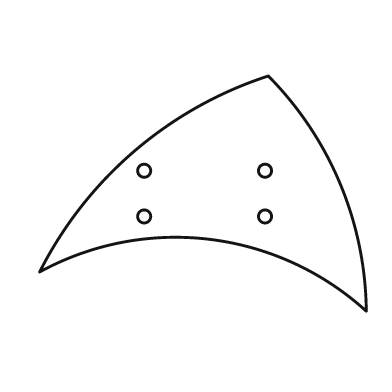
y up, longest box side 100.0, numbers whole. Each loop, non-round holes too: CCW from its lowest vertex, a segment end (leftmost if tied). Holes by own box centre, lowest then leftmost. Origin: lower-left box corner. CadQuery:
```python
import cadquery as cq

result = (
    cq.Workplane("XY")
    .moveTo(100.0, 0.0)
    .threePointArc((92.0, 39.0), (70.0, 72.0))
    .threePointArc((29.0, 49.0), (0.0, 12.0))
    .threePointArc((52.0, 22.0), (100.0, 0.0))
    .close()
    .moveTo(32.0, 29.0)
    .circle(2.0)
    .moveTo(69.0, 29.0)
    .circle(2.0)
    .moveTo(32.0, 43.0)
    .circle(2.0)
    .moveTo(69.0, 43.0)
    .circle(2.0)
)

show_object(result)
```